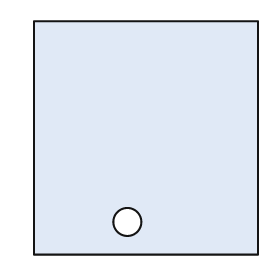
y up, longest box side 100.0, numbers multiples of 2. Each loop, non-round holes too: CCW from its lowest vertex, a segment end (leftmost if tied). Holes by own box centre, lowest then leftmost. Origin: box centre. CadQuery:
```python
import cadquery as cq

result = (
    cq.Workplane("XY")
    .moveTo(-48.0, -50.0)
    .lineTo(48.0, -50.0)
    .lineTo(48.0, 50.0)
    .lineTo(-48.0, 50.0)
    .close()
    .moveTo(-8.0, -36.0)
    .circle(6.0)
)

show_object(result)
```